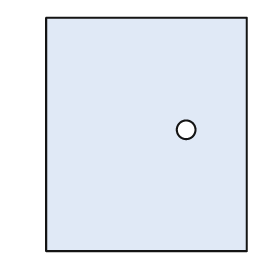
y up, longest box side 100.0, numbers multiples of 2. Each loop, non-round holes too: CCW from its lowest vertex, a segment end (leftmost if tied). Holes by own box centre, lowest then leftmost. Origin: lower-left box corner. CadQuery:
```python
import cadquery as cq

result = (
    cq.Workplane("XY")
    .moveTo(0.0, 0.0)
    .lineTo(86.0, 0.0)
    .lineTo(86.0, 100.0)
    .lineTo(0.0, 100.0)
    .close()
    .moveTo(60.0, 52.0)
    .circle(4.0)
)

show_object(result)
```